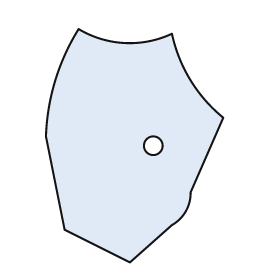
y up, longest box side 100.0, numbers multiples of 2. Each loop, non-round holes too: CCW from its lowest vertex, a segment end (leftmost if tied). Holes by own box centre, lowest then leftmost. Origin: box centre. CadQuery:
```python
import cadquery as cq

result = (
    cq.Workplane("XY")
    .moveTo(-2.0, -50.0)
    .lineTo(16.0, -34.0)
    .threePointArc((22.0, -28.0), (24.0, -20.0))
    .lineTo(38.0, 12.0)
    .threePointArc((24.0, 28.0), (16.0, 48.0))
    .threePointArc((-4.0, 44.0), (-24.0, 50.0))
    .threePointArc((-34.0, 28.0), (-38.0, 4.0))
    .lineTo(-30.0, -36.0)
    .close()
    .moveTo(8.0, 0.0)
    .circle(4.0)
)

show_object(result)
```